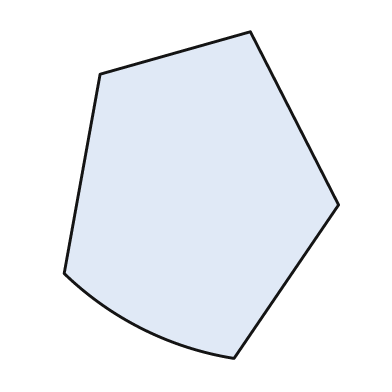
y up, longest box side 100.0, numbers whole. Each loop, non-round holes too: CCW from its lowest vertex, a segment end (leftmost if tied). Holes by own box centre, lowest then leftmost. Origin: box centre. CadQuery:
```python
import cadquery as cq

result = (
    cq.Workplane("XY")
    .moveTo(10.0, -50.0)
    .lineTo(42.0, -3.0)
    .lineTo(15.0, 50.0)
    .lineTo(-31.0, 37.0)
    .lineTo(-42.0, -24.0)
    .threePointArc((-18.0, -41.0), (10.0, -50.0))
    .close()
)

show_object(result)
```